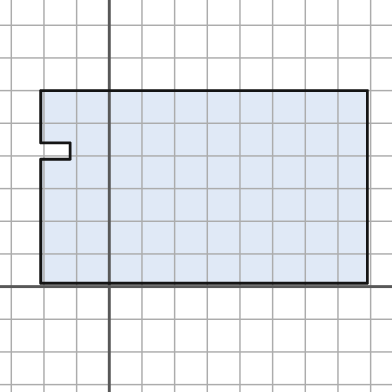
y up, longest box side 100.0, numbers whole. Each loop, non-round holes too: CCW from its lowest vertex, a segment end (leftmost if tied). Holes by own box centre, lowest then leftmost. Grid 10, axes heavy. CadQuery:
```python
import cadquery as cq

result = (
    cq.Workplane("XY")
    .moveTo(-21.0, 1.0)
    .lineTo(79.0, 1.0)
    .lineTo(79.0, 60.0)
    .lineTo(-21.0, 60.0)
    .lineTo(-21.0, 44.0)
    .lineTo(-12.0, 44.0)
    .lineTo(-12.0, 39.0)
    .lineTo(-21.0, 39.0)
    .close()
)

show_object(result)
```